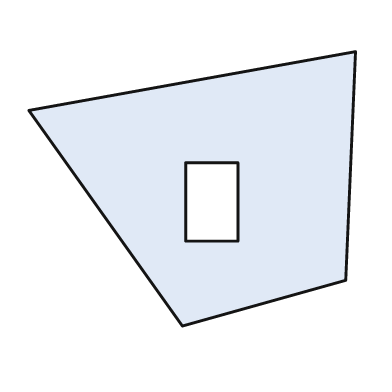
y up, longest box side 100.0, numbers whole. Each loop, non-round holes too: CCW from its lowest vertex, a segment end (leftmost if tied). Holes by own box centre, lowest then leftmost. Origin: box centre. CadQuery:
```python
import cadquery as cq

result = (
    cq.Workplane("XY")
    .moveTo(-3.0, -42.0)
    .lineTo(47.0, -28.0)
    .lineTo(50.0, 42.0)
    .lineTo(-50.0, 24.0)
    .close()
    .moveTo(-2.0, -16.0)
    .lineTo(14.0, -16.0)
    .lineTo(14.0, 8.0)
    .lineTo(-2.0, 8.0)
    .close()
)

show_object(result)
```